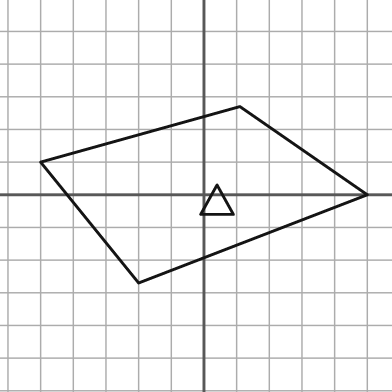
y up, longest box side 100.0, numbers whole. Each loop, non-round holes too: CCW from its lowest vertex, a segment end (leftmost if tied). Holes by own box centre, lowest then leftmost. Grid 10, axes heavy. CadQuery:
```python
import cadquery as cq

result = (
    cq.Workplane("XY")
    .moveTo(-20.0, -27.0)
    .lineTo(50.0, 0.0)
    .lineTo(11.0, 27.0)
    .lineTo(-50.0, 10.0)
    .close()
    .moveTo(-1.0, -6.0)
    .lineTo(9.0, -6.0)
    .lineTo(4.0, 3.0)
    .close()
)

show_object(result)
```